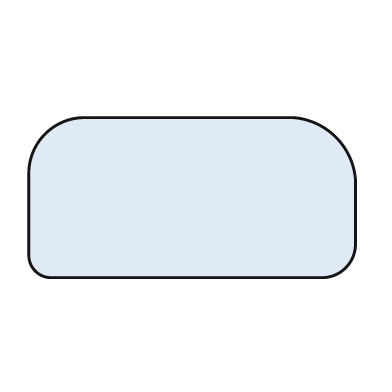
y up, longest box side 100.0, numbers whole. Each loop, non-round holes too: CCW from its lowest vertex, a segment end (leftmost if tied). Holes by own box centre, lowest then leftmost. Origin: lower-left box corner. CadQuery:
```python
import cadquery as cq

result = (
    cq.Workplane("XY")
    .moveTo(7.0, 0.0)
    .lineTo(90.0, 0.0)
    .threePointArc((97.0, 3.0), (100.0, 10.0))
    .lineTo(100.0, 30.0)
    .threePointArc((94.0, 43.0), (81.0, 49.0))
    .lineTo(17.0, 49.0)
    .threePointArc((5.0, 44.0), (0.0, 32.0))
    .lineTo(0.0, 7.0)
    .threePointArc((2.0, 2.0), (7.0, 0.0))
    .close()
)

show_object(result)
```